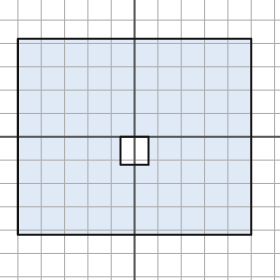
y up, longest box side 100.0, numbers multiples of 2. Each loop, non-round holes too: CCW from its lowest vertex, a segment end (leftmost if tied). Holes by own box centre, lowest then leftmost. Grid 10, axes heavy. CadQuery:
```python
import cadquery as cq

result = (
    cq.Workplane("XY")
    .moveTo(-50.0, -42.0)
    .lineTo(50.0, -42.0)
    .lineTo(50.0, 42.0)
    .lineTo(-50.0, 42.0)
    .close()
    .moveTo(-6.0, -12.0)
    .lineTo(6.0, -12.0)
    .lineTo(6.0, 0.0)
    .lineTo(-6.0, 0.0)
    .close()
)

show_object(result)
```